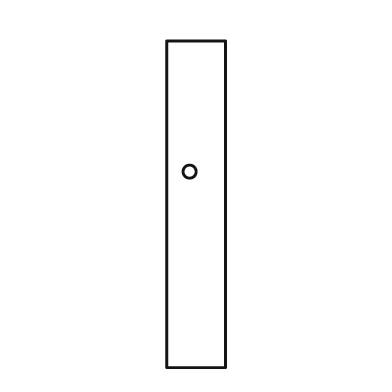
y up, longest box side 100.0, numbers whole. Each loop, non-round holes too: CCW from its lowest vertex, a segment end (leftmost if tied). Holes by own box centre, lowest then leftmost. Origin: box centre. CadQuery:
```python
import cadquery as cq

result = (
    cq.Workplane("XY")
    .moveTo(-9.0, -50.0)
    .lineTo(9.0, -50.0)
    .lineTo(9.0, 50.0)
    .lineTo(-9.0, 50.0)
    .close()
    .moveTo(-2.0, 10.0)
    .circle(2.0)
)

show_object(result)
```